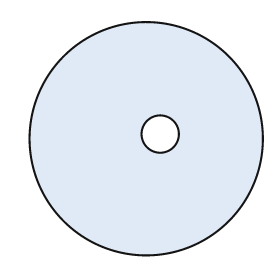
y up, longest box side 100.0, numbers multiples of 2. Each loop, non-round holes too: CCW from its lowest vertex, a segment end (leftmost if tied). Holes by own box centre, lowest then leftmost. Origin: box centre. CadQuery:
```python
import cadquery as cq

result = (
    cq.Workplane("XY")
    .moveTo(0.0, 0.0)
    .circle(50.0)
    .moveTo(6.0, 2.0)
    .circle(8.0)
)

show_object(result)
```